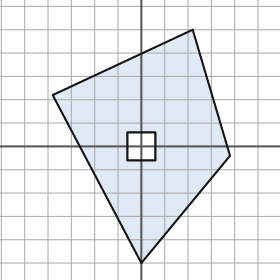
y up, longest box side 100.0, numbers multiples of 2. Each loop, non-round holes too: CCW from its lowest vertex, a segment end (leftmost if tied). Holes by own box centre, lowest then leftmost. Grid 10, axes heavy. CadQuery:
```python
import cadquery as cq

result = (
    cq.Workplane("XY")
    .moveTo(0.0, -50.0)
    .lineTo(38.0, -4.0)
    .lineTo(22.0, 50.0)
    .lineTo(-38.0, 22.0)
    .close()
    .moveTo(-6.0, -6.0)
    .lineTo(6.0, -6.0)
    .lineTo(6.0, 6.0)
    .lineTo(-6.0, 6.0)
    .close()
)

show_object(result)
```